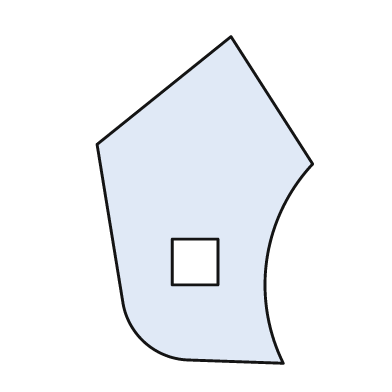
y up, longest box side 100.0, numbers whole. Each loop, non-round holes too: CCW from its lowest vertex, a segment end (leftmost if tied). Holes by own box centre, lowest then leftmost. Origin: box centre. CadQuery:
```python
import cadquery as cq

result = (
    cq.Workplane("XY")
    .moveTo(24.0, -50.0)
    .threePointArc((19.0, -18.0), (33.0, 11.0))
    .lineTo(8.0, 50.0)
    .lineTo(-33.0, 17.0)
    .lineTo(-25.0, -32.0)
    .threePointArc((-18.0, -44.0), (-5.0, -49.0))
    .close()
    .moveTo(-10.0, -26.0)
    .lineTo(4.0, -26.0)
    .lineTo(4.0, -12.0)
    .lineTo(-10.0, -12.0)
    .close()
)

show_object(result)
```